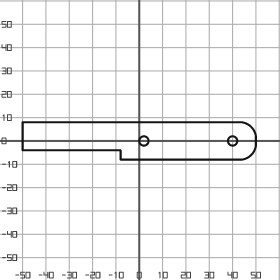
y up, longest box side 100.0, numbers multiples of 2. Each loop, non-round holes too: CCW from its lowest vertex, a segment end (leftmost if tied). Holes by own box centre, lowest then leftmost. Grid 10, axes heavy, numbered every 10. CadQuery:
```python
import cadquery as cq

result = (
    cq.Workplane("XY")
    .moveTo(-8.0, -8.0)
    .lineTo(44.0, -8.0)
    .threePointArc((48.0, -6.0), (50.0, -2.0))
    .lineTo(50.0, 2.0)
    .threePointArc((48.0, 6.0), (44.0, 8.0))
    .lineTo(-50.0, 8.0)
    .lineTo(-50.0, -4.0)
    .lineTo(-8.0, -4.0)
    .close()
    .moveTo(2.0, 0.0)
    .circle(2.0)
    .moveTo(40.0, 0.0)
    .circle(2.0)
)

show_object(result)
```